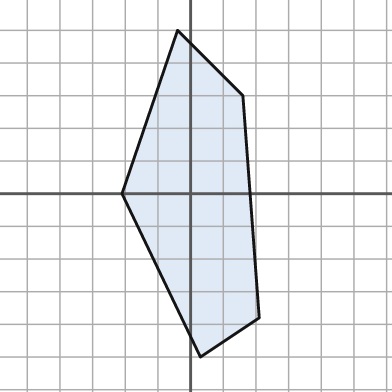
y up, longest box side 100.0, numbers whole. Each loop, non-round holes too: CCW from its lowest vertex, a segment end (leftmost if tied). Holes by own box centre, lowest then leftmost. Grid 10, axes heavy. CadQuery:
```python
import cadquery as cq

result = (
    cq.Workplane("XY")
    .moveTo(3.0, -50.0)
    .lineTo(21.0, -38.0)
    .lineTo(16.0, 30.0)
    .lineTo(-4.0, 50.0)
    .lineTo(-21.0, 0.0)
    .close()
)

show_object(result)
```